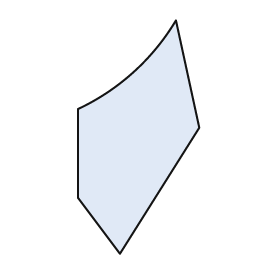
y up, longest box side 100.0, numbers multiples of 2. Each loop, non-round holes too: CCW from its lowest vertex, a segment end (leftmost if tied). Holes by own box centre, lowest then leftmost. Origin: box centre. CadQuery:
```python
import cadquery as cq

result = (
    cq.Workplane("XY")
    .moveTo(-8.0, -50.0)
    .lineTo(26.0, 4.0)
    .lineTo(16.0, 50.0)
    .threePointArc((-2.0, 28.0), (-26.0, 12.0))
    .lineTo(-26.0, -26.0)
    .close()
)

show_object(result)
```